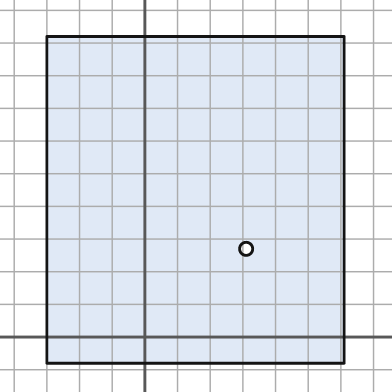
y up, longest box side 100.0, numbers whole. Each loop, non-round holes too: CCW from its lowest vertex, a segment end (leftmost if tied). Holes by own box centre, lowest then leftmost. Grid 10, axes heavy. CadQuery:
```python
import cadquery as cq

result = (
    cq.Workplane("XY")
    .moveTo(-30.0, -8.0)
    .lineTo(61.0, -8.0)
    .lineTo(61.0, 92.0)
    .lineTo(-30.0, 92.0)
    .close()
    .moveTo(31.0, 27.0)
    .circle(2.0)
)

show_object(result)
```